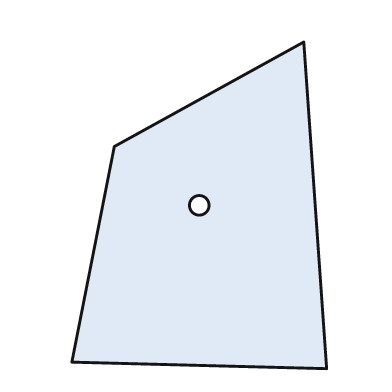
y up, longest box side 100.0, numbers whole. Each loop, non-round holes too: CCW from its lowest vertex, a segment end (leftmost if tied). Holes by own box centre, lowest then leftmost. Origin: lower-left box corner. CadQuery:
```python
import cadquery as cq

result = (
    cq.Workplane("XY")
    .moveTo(78.0, 0.0)
    .lineTo(71.0, 100.0)
    .lineTo(13.0, 68.0)
    .lineTo(0.0, 2.0)
    .close()
    .moveTo(39.0, 50.0)
    .circle(3.0)
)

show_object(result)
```